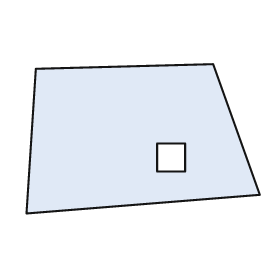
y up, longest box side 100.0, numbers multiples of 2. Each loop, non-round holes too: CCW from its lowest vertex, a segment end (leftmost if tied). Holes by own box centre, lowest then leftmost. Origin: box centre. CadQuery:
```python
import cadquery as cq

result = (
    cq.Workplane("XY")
    .moveTo(-50.0, -32.0)
    .lineTo(50.0, -24.0)
    .lineTo(30.0, 32.0)
    .lineTo(-46.0, 30.0)
    .close()
    .moveTo(6.0, -14.0)
    .lineTo(18.0, -14.0)
    .lineTo(18.0, -2.0)
    .lineTo(6.0, -2.0)
    .close()
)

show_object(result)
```